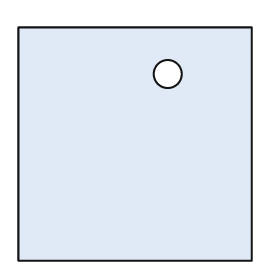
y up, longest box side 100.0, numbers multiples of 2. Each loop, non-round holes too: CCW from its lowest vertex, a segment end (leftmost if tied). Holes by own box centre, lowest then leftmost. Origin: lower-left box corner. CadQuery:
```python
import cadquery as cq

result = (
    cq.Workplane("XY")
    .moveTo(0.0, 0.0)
    .lineTo(100.0, 0.0)
    .lineTo(100.0, 100.0)
    .lineTo(0.0, 100.0)
    .close()
    .moveTo(64.0, 80.0)
    .circle(6.0)
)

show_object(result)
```